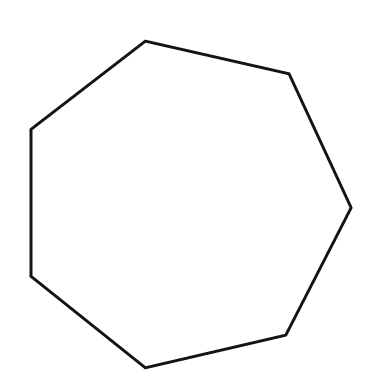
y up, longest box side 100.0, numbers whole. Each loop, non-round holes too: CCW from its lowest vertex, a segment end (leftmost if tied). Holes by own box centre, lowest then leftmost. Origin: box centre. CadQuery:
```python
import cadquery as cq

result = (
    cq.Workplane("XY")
    .moveTo(-14.0, -50.0)
    .lineTo(29.0, -40.0)
    .lineTo(49.0, -1.0)
    .lineTo(30.0, 40.0)
    .lineTo(-14.0, 50.0)
    .lineTo(-49.0, 23.0)
    .lineTo(-49.0, -22.0)
    .close()
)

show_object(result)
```